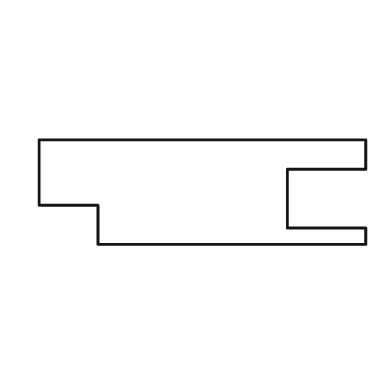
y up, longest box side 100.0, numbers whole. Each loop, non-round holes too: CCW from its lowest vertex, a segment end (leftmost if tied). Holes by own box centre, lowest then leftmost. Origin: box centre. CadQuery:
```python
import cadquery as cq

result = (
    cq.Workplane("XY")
    .moveTo(-32.0, -16.0)
    .lineTo(50.0, -16.0)
    .lineTo(50.0, -11.0)
    .lineTo(26.0, -11.0)
    .lineTo(26.0, 7.0)
    .lineTo(50.0, 7.0)
    .lineTo(50.0, 16.0)
    .lineTo(-50.0, 16.0)
    .lineTo(-50.0, -4.0)
    .lineTo(-32.0, -4.0)
    .close()
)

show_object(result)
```